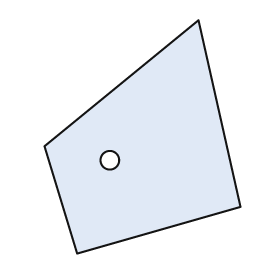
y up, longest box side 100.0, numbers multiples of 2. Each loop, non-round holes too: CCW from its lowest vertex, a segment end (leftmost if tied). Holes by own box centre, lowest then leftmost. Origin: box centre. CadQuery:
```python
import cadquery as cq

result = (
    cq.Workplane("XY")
    .moveTo(-28.0, -50.0)
    .lineTo(42.0, -30.0)
    .lineTo(24.0, 50.0)
    .lineTo(-42.0, -4.0)
    .close()
    .moveTo(-14.0, -10.0)
    .circle(4.0)
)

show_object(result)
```